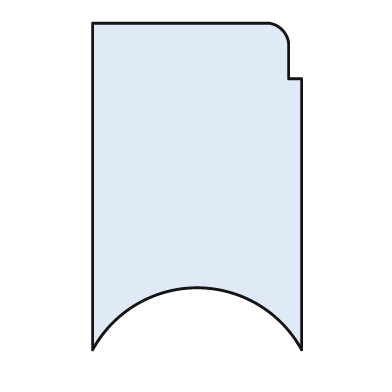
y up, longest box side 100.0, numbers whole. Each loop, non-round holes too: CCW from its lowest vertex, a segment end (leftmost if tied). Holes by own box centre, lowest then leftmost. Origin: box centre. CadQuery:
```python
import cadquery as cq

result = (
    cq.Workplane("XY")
    .moveTo(-32.0, -50.0)
    .threePointArc((0.0, -31.0), (32.0, -50.0))
    .lineTo(32.0, 33.0)
    .lineTo(28.0, 33.0)
    .lineTo(28.0, 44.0)
    .threePointArc((26.0, 48.0), (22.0, 50.0))
    .lineTo(-32.0, 50.0)
    .close()
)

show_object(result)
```